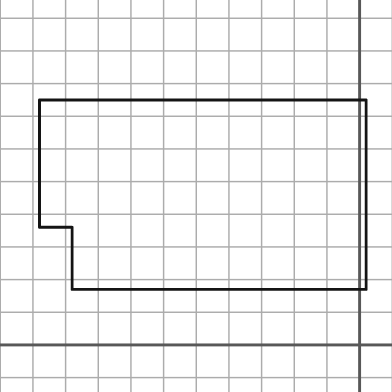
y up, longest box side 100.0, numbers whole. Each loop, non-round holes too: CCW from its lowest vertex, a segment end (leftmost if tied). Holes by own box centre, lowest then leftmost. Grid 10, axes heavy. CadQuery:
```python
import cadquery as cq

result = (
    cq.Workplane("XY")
    .moveTo(-88.0, 17.0)
    .lineTo(2.0, 17.0)
    .lineTo(2.0, 75.0)
    .lineTo(-98.0, 75.0)
    .lineTo(-98.0, 36.0)
    .lineTo(-88.0, 36.0)
    .close()
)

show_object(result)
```